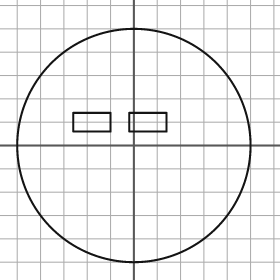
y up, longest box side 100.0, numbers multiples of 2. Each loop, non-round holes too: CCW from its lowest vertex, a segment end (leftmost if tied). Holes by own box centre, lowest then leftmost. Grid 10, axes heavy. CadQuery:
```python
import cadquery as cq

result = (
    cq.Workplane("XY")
    .moveTo(0.0, 0.0)
    .circle(50.0)
    .moveTo(-26.0, 6.0)
    .lineTo(-10.0, 6.0)
    .lineTo(-10.0, 14.0)
    .lineTo(-26.0, 14.0)
    .close()
    .moveTo(-2.0, 6.0)
    .lineTo(14.0, 6.0)
    .lineTo(14.0, 14.0)
    .lineTo(-2.0, 14.0)
    .close()
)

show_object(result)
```